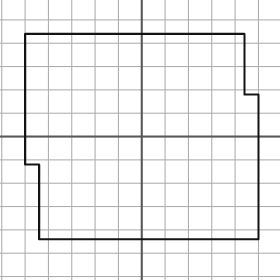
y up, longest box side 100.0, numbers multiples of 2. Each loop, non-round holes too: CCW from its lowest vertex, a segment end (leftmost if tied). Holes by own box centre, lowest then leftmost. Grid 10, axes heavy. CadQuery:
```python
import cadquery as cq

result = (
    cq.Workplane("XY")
    .moveTo(-44.0, -44.0)
    .lineTo(50.0, -44.0)
    .lineTo(50.0, 18.0)
    .lineTo(44.0, 18.0)
    .lineTo(44.0, 44.0)
    .lineTo(-50.0, 44.0)
    .lineTo(-50.0, -12.0)
    .lineTo(-44.0, -12.0)
    .close()
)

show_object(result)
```